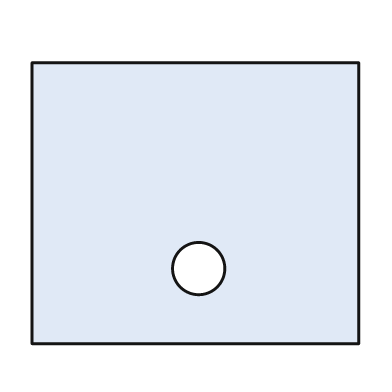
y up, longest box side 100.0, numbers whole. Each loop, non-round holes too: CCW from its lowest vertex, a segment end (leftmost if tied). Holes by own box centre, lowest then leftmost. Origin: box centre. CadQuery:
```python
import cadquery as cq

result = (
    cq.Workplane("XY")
    .moveTo(-50.0, -43.0)
    .lineTo(50.0, -43.0)
    .lineTo(50.0, 43.0)
    .lineTo(-50.0, 43.0)
    .close()
    .moveTo(1.0, -20.0)
    .circle(8.0)
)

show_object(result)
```